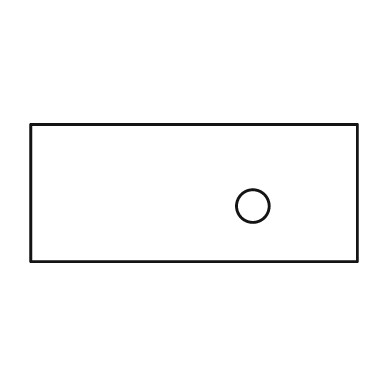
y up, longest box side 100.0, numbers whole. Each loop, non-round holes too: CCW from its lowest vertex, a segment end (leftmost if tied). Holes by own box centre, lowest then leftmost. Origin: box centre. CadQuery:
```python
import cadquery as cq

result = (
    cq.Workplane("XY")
    .moveTo(-50.0, -21.0)
    .lineTo(50.0, -21.0)
    .lineTo(50.0, 21.0)
    .lineTo(-50.0, 21.0)
    .close()
    .moveTo(18.0, -4.0)
    .circle(5.0)
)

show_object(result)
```